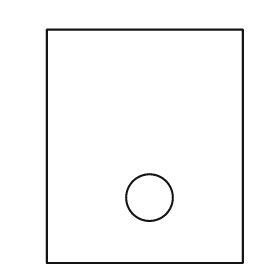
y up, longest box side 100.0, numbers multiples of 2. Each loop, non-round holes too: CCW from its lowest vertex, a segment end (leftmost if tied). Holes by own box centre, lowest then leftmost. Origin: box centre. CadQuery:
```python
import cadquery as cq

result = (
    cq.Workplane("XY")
    .moveTo(-42.0, -50.0)
    .lineTo(42.0, -50.0)
    .lineTo(42.0, 50.0)
    .lineTo(-42.0, 50.0)
    .close()
    .moveTo(2.0, -22.0)
    .circle(10.0)
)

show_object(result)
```